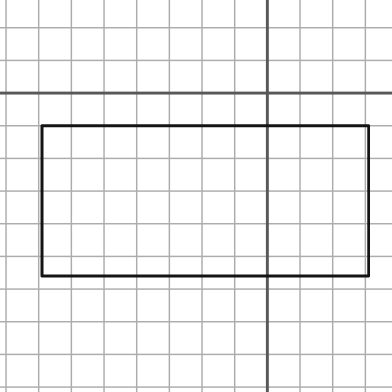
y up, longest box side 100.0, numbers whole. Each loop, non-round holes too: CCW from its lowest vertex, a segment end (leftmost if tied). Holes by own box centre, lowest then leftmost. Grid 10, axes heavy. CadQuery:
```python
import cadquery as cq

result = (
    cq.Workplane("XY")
    .moveTo(-69.0, -56.0)
    .lineTo(31.0, -56.0)
    .lineTo(31.0, -10.0)
    .lineTo(-69.0, -10.0)
    .close()
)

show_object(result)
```